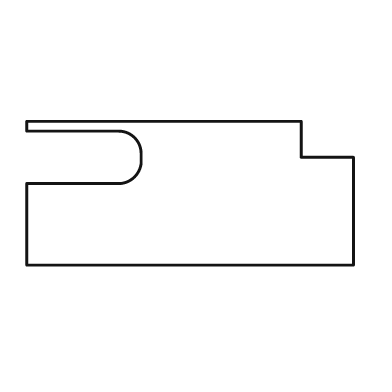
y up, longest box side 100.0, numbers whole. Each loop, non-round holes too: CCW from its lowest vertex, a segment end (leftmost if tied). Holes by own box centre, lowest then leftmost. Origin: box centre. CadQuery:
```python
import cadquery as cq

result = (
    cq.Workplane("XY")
    .moveTo(-50.0, -22.0)
    .lineTo(50.0, -22.0)
    .lineTo(50.0, 11.0)
    .lineTo(34.0, 11.0)
    .lineTo(34.0, 22.0)
    .lineTo(-50.0, 22.0)
    .lineTo(-50.0, 19.0)
    .lineTo(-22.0, 19.0)
    .threePointArc((-17.0, 17.0), (-15.0, 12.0))
    .lineTo(-15.0, 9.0)
    .threePointArc((-17.0, 5.0), (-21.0, 3.0))
    .lineTo(-50.0, 3.0)
    .close()
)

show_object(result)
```